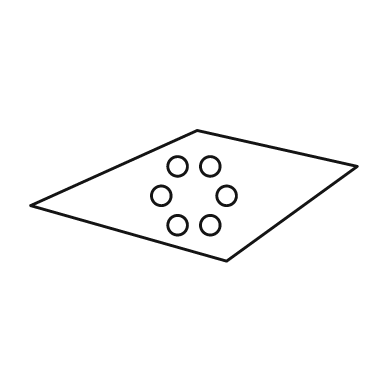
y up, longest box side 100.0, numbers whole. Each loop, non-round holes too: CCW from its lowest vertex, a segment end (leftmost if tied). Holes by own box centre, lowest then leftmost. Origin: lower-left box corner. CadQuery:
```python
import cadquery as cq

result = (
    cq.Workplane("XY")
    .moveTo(60.0, 0.0)
    .lineTo(100.0, 29.0)
    .lineTo(51.0, 40.0)
    .lineTo(0.0, 17.0)
    .close()
    .moveTo(45.0, 11.0)
    .circle(3.0)
    .moveTo(55.0, 11.0)
    .circle(3.0)
    .moveTo(40.0, 20.0)
    .circle(3.0)
    .moveTo(60.0, 20.0)
    .circle(3.0)
    .moveTo(45.0, 29.0)
    .circle(3.0)
    .moveTo(55.0, 29.0)
    .circle(3.0)
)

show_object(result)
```